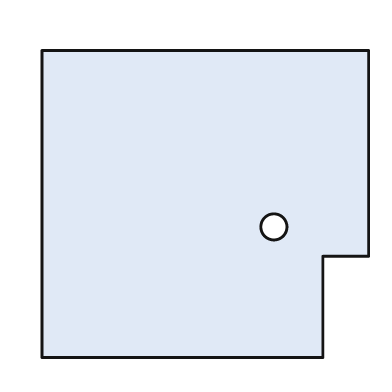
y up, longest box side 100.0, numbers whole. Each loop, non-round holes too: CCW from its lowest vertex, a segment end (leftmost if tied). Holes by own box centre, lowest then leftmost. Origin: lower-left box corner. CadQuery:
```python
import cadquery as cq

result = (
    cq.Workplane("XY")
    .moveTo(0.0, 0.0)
    .lineTo(86.0, 0.0)
    .lineTo(86.0, 31.0)
    .lineTo(100.0, 31.0)
    .lineTo(100.0, 94.0)
    .lineTo(0.0, 94.0)
    .close()
    .moveTo(71.0, 40.0)
    .circle(4.0)
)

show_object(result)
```